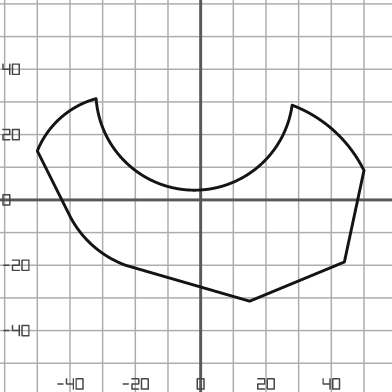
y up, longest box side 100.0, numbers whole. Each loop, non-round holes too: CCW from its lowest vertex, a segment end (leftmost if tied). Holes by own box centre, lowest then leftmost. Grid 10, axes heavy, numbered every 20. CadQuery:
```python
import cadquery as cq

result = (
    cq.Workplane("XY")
    .moveTo(15.0, -31.0)
    .lineTo(44.0, -19.0)
    .lineTo(50.0, 9.0)
    .threePointArc((41.0, 21.0), (28.0, 29.0))
    .threePointArc((-3.0, 3.0), (-32.0, 31.0))
    .threePointArc((-43.0, 25.0), (-50.0, 15.0))
    .lineTo(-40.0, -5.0)
    .threePointArc((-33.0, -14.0), (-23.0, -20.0))
    .close()
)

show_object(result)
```